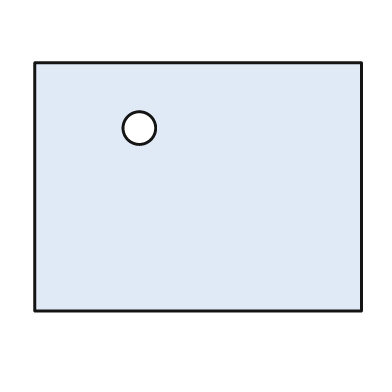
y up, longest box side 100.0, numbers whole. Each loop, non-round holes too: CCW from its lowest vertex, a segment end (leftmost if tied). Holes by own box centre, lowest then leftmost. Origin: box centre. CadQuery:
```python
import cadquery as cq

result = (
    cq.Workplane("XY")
    .moveTo(-50.0, -38.0)
    .lineTo(50.0, -38.0)
    .lineTo(50.0, 38.0)
    .lineTo(-50.0, 38.0)
    .close()
    .moveTo(-18.0, 18.0)
    .circle(5.0)
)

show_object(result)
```